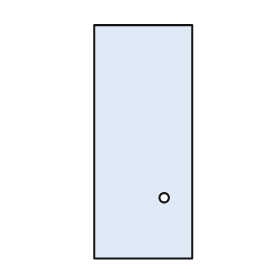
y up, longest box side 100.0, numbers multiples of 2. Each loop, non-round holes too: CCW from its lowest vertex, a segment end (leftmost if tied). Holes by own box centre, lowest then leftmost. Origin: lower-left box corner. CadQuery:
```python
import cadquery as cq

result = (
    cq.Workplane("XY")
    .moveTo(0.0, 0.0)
    .lineTo(42.0, 0.0)
    .lineTo(42.0, 100.0)
    .lineTo(0.0, 100.0)
    .close()
    .moveTo(30.0, 26.0)
    .circle(2.0)
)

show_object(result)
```